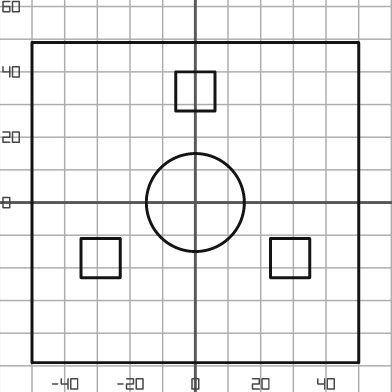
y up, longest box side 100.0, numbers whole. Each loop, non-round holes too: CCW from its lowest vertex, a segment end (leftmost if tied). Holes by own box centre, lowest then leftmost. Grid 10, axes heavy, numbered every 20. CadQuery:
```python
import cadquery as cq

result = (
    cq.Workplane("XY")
    .moveTo(-50.0, -49.0)
    .lineTo(50.0, -49.0)
    .lineTo(50.0, 49.0)
    .lineTo(-50.0, 49.0)
    .close()
    .moveTo(-35.0, -23.0)
    .lineTo(-23.0, -23.0)
    .lineTo(-23.0, -11.0)
    .lineTo(-35.0, -11.0)
    .close()
    .moveTo(23.0, -23.0)
    .lineTo(35.0, -23.0)
    .lineTo(35.0, -11.0)
    .lineTo(23.0, -11.0)
    .close()
    .moveTo(0.0, 0.0)
    .circle(15.0)
    .moveTo(-6.0, 28.0)
    .lineTo(6.0, 28.0)
    .lineTo(6.0, 40.0)
    .lineTo(-6.0, 40.0)
    .close()
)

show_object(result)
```